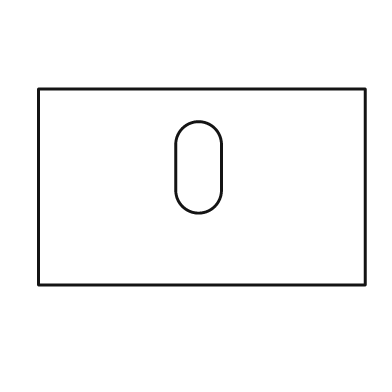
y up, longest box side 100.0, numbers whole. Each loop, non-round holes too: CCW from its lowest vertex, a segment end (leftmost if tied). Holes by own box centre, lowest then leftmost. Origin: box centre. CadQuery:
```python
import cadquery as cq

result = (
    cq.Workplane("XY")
    .moveTo(-50.0, -30.0)
    .lineTo(50.0, -30.0)
    .lineTo(50.0, 30.0)
    .lineTo(-50.0, 30.0)
    .close()
    .moveTo(-8.0, -1.0)
    .threePointArc((-1.0, -8.0), (6.0, -1.0))
    .lineTo(6.0, 13.0)
    .threePointArc((-1.0, 20.0), (-8.0, 13.0))
    .close()
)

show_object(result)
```